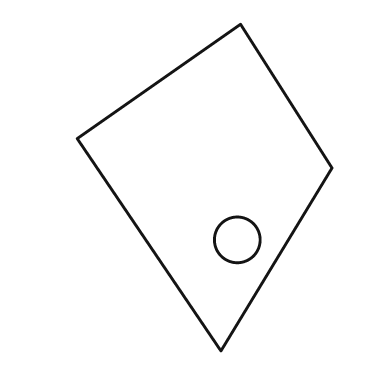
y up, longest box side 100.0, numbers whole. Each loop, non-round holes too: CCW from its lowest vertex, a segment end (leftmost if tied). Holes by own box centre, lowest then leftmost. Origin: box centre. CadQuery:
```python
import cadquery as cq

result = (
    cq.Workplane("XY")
    .moveTo(5.0, -50.0)
    .lineTo(39.0, 6.0)
    .lineTo(11.0, 50.0)
    .lineTo(-39.0, 15.0)
    .close()
    .moveTo(10.0, -16.0)
    .circle(7.0)
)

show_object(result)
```